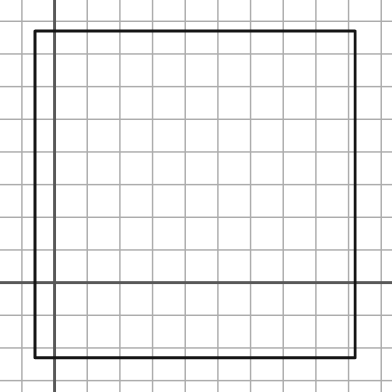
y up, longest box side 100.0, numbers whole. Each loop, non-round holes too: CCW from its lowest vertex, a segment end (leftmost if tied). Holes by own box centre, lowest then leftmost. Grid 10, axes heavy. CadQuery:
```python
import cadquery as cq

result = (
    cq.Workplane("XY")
    .moveTo(-6.0, -23.0)
    .lineTo(92.0, -23.0)
    .lineTo(92.0, 77.0)
    .lineTo(-6.0, 77.0)
    .close()
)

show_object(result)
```